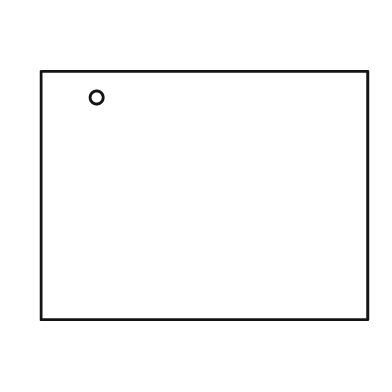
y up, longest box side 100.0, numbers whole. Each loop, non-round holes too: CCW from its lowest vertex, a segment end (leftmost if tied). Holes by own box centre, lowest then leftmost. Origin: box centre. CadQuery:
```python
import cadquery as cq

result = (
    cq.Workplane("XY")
    .moveTo(-50.0, -38.0)
    .lineTo(50.0, -38.0)
    .lineTo(50.0, 38.0)
    .lineTo(-50.0, 38.0)
    .close()
    .moveTo(-33.0, 30.0)
    .circle(2.0)
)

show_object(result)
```